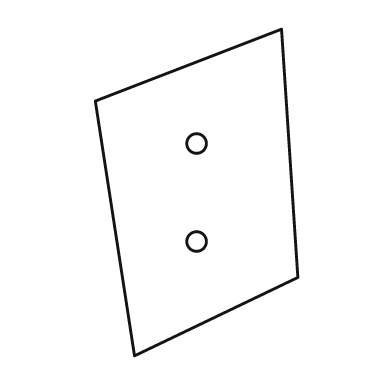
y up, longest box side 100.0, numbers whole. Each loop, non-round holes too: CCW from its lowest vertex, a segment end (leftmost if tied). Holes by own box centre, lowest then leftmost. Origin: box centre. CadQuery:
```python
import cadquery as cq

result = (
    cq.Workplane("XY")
    .moveTo(-19.0, -50.0)
    .lineTo(31.0, -26.0)
    .lineTo(26.0, 50.0)
    .lineTo(-31.0, 28.0)
    .close()
    .moveTo(0.0, -15.0)
    .circle(3.0)
    .moveTo(0.0, 15.0)
    .circle(3.0)
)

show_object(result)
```